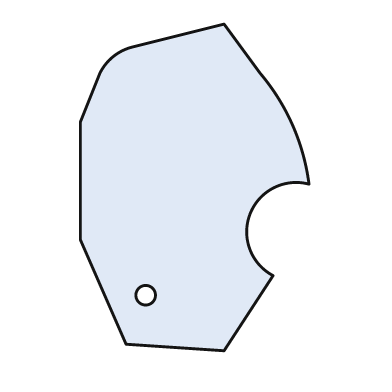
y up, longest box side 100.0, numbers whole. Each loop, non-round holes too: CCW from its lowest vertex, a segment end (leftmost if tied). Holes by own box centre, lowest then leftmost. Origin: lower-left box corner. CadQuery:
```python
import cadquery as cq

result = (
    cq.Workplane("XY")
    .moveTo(44.0, 0.0)
    .lineTo(59.0, 23.0)
    .threePointArc((52.0, 42.0), (70.0, 51.0))
    .threePointArc((65.0, 69.0), (55.0, 85.0))
    .lineTo(44.0, 100.0)
    .lineTo(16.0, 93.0)
    .threePointArc((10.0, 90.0), (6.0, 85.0))
    .lineTo(0.0, 70.0)
    .lineTo(0.0, 34.0)
    .lineTo(14.0, 2.0)
    .close()
    .moveTo(20.0, 17.0)
    .circle(3.0)
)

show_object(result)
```